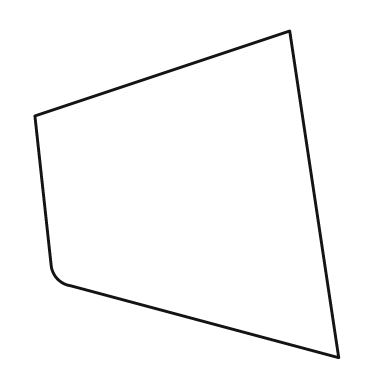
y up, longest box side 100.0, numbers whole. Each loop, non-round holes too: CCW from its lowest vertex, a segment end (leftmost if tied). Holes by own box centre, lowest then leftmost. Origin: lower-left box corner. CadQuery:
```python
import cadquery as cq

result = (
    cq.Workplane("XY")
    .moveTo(93.0, 0.0)
    .lineTo(78.0, 100.0)
    .lineTo(0.0, 74.0)
    .lineTo(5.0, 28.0)
    .threePointArc((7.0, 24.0), (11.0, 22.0))
    .close()
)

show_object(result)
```